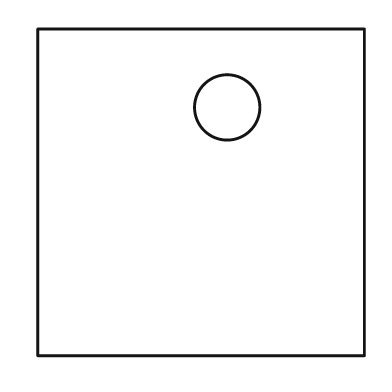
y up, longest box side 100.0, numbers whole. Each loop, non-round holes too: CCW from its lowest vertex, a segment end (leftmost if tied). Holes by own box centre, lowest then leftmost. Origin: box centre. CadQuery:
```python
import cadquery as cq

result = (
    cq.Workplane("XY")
    .moveTo(-50.0, -50.0)
    .lineTo(50.0, -50.0)
    .lineTo(50.0, 50.0)
    .lineTo(-50.0, 50.0)
    .close()
    .moveTo(8.0, 26.0)
    .circle(10.0)
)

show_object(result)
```